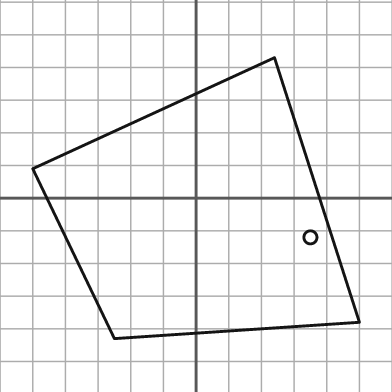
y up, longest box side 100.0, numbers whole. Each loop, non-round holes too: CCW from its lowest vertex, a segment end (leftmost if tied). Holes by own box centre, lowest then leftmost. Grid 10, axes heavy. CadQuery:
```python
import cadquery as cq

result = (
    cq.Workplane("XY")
    .moveTo(-25.0, -43.0)
    .lineTo(50.0, -38.0)
    .lineTo(24.0, 43.0)
    .lineTo(-50.0, 9.0)
    .close()
    .moveTo(35.0, -12.0)
    .circle(2.0)
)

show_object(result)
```